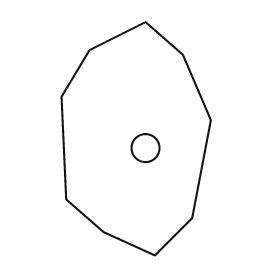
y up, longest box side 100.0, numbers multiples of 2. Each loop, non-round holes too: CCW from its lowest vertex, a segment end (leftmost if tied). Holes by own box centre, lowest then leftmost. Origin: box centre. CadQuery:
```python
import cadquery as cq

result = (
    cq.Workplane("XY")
    .moveTo(8.0, -50.0)
    .lineTo(24.0, -34.0)
    .lineTo(32.0, 8.0)
    .lineTo(20.0, 36.0)
    .lineTo(4.0, 50.0)
    .lineTo(-20.0, 38.0)
    .lineTo(-32.0, 18.0)
    .lineTo(-30.0, -26.0)
    .lineTo(-14.0, -40.0)
    .close()
    .moveTo(4.0, -4.0)
    .circle(6.0)
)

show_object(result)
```